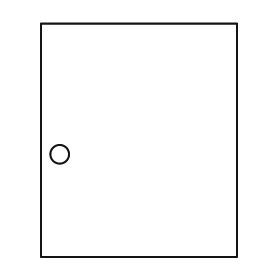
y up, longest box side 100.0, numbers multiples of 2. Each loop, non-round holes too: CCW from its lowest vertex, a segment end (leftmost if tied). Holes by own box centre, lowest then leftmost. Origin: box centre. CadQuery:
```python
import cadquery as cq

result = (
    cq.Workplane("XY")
    .moveTo(-42.0, -50.0)
    .lineTo(42.0, -50.0)
    .lineTo(42.0, 50.0)
    .lineTo(-42.0, 50.0)
    .close()
    .moveTo(-34.0, -6.0)
    .circle(4.0)
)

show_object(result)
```